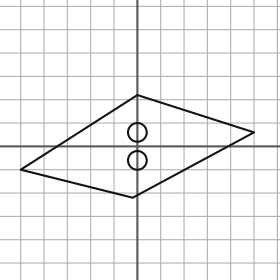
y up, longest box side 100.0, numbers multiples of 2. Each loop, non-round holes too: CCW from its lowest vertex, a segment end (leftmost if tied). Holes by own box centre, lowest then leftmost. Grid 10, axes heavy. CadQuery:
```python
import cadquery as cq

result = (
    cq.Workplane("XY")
    .moveTo(-2.0, -22.0)
    .lineTo(50.0, 6.0)
    .lineTo(0.0, 22.0)
    .lineTo(-50.0, -10.0)
    .close()
    .moveTo(0.0, -6.0)
    .circle(4.0)
    .moveTo(0.0, 6.0)
    .circle(4.0)
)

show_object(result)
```